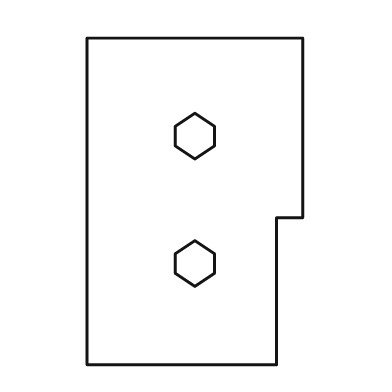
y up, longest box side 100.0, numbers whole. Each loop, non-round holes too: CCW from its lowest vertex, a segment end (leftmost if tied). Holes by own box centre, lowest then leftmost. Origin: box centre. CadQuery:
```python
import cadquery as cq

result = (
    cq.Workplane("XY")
    .moveTo(-33.0, -50.0)
    .lineTo(25.0, -50.0)
    .lineTo(25.0, -5.0)
    .lineTo(33.0, -5.0)
    .lineTo(33.0, 50.0)
    .lineTo(-33.0, 50.0)
    .close()
    .moveTo(0.0, -26.0)
    .lineTo(6.0, -22.0)
    .lineTo(6.0, -16.0)
    .lineTo(0.0, -12.0)
    .lineTo(-6.0, -16.0)
    .lineTo(-6.0, -22.0)
    .close()
    .moveTo(0.0, 13.0)
    .lineTo(6.0, 17.0)
    .lineTo(6.0, 23.0)
    .lineTo(0.0, 27.0)
    .lineTo(-6.0, 23.0)
    .lineTo(-6.0, 17.0)
    .close()
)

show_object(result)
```